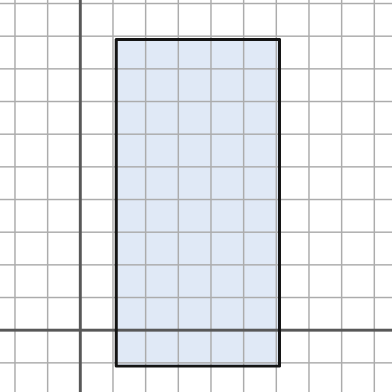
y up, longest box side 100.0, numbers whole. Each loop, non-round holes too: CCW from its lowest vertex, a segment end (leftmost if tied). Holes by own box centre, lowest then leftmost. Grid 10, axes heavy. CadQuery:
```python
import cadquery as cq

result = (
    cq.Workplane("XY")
    .moveTo(11.0, -11.0)
    .lineTo(61.0, -11.0)
    .lineTo(61.0, 89.0)
    .lineTo(11.0, 89.0)
    .close()
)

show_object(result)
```